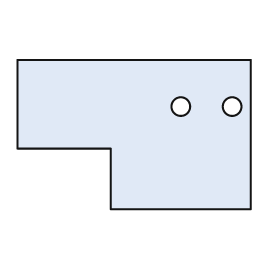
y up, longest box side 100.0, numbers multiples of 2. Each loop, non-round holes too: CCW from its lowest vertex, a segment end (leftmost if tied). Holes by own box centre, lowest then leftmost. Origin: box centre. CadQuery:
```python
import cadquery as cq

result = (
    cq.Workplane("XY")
    .moveTo(-10.0, -32.0)
    .lineTo(50.0, -32.0)
    .lineTo(50.0, 32.0)
    .lineTo(-50.0, 32.0)
    .lineTo(-50.0, -6.0)
    .lineTo(-10.0, -6.0)
    .close()
    .moveTo(20.0, 12.0)
    .circle(4.0)
    .moveTo(42.0, 12.0)
    .circle(4.0)
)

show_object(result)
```